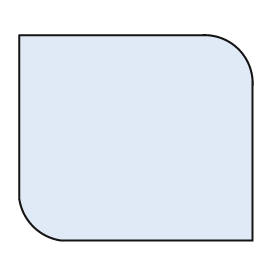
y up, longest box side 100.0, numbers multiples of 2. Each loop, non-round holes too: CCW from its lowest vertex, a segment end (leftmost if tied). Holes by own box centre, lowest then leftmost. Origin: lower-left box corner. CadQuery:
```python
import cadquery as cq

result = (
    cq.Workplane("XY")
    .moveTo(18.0, 0.0)
    .lineTo(100.0, 0.0)
    .lineTo(100.0, 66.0)
    .threePointArc((94.0, 82.0), (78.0, 88.0))
    .lineTo(0.0, 88.0)
    .lineTo(0.0, 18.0)
    .threePointArc((6.0, 6.0), (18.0, 0.0))
    .close()
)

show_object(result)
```